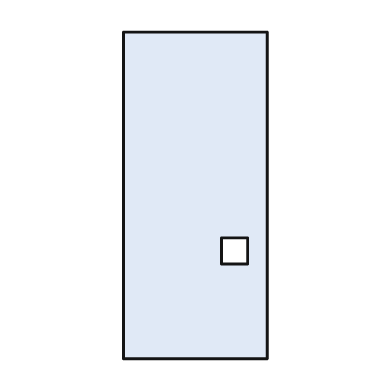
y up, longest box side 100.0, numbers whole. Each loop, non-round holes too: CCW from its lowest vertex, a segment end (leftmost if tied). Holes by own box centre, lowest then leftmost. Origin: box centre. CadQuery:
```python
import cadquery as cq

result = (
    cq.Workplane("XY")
    .moveTo(-22.0, -50.0)
    .lineTo(22.0, -50.0)
    .lineTo(22.0, 50.0)
    .lineTo(-22.0, 50.0)
    .close()
    .moveTo(8.0, -21.0)
    .lineTo(16.0, -21.0)
    .lineTo(16.0, -13.0)
    .lineTo(8.0, -13.0)
    .close()
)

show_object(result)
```